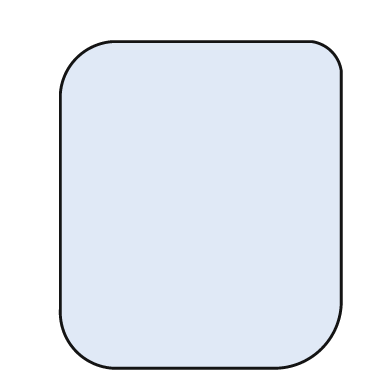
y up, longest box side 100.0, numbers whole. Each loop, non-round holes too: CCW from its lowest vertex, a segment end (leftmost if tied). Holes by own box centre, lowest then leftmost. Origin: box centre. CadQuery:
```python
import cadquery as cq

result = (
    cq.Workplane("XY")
    .moveTo(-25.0, -50.0)
    .lineTo(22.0, -50.0)
    .threePointArc((37.0, -44.0), (43.0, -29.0))
    .lineTo(43.0, 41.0)
    .threePointArc((40.0, 47.0), (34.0, 50.0))
    .lineTo(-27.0, 50.0)
    .threePointArc((-38.0, 45.0), (-43.0, 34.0))
    .lineTo(-43.0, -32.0)
    .threePointArc((-38.0, -45.0), (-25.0, -50.0))
    .close()
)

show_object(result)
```